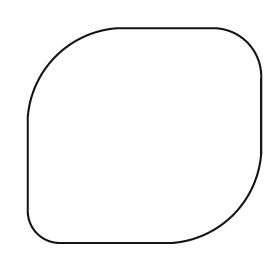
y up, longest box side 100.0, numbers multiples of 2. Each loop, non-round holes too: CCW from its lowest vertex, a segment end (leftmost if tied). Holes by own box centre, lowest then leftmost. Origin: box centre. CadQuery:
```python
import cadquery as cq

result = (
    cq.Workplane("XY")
    .moveTo(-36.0, -46.0)
    .lineTo(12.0, -46.0)
    .threePointArc((38.0, -34.0), (50.0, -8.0))
    .lineTo(50.0, 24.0)
    .threePointArc((44.0, 40.0), (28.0, 46.0))
    .lineTo(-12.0, 46.0)
    .threePointArc((-38.0, 34.0), (-50.0, 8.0))
    .lineTo(-50.0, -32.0)
    .threePointArc((-46.0, -42.0), (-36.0, -46.0))
    .close()
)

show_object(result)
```